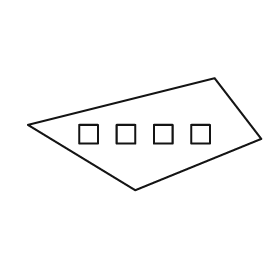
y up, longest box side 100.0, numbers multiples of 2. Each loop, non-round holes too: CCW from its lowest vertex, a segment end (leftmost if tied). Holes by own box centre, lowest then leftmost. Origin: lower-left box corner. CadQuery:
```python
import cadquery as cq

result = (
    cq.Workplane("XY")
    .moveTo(46.0, 0.0)
    .lineTo(100.0, 22.0)
    .lineTo(80.0, 48.0)
    .lineTo(0.0, 28.0)
    .close()
    .moveTo(22.0, 20.0)
    .lineTo(30.0, 20.0)
    .lineTo(30.0, 28.0)
    .lineTo(22.0, 28.0)
    .close()
    .moveTo(38.0, 20.0)
    .lineTo(46.0, 20.0)
    .lineTo(46.0, 28.0)
    .lineTo(38.0, 28.0)
    .close()
    .moveTo(54.0, 20.0)
    .lineTo(62.0, 20.0)
    .lineTo(62.0, 28.0)
    .lineTo(54.0, 28.0)
    .close()
    .moveTo(70.0, 20.0)
    .lineTo(78.0, 20.0)
    .lineTo(78.0, 28.0)
    .lineTo(70.0, 28.0)
    .close()
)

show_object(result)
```